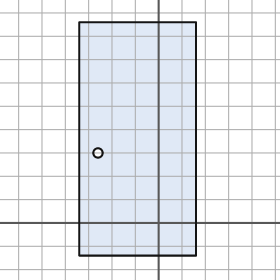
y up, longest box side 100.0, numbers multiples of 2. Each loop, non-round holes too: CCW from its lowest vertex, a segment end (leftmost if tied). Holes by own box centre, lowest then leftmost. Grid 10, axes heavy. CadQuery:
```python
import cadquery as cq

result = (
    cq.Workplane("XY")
    .moveTo(-34.0, -14.0)
    .lineTo(16.0, -14.0)
    .lineTo(16.0, 86.0)
    .lineTo(-34.0, 86.0)
    .close()
    .moveTo(-26.0, 30.0)
    .circle(2.0)
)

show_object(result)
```